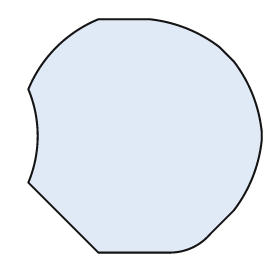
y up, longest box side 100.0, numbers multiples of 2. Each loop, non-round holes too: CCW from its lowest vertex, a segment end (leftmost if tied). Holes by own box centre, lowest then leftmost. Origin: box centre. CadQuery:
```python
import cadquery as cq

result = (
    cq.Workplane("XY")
    .moveTo(-20.0, -50.0)
    .lineTo(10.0, -50.0)
    .threePointArc((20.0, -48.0), (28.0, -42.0))
    .lineTo(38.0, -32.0)
    .threePointArc((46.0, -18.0), (50.0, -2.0))
    .lineTo(50.0, 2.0)
    .threePointArc((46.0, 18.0), (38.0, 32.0))
    .lineTo(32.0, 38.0)
    .threePointArc((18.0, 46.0), (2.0, 50.0))
    .lineTo(-20.0, 50.0)
    .threePointArc((-38.0, 38.0), (-50.0, 20.0))
    .threePointArc((-46.0, 0.0), (-50.0, -20.0))
    .close()
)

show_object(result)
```